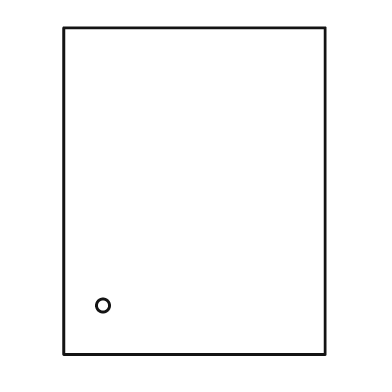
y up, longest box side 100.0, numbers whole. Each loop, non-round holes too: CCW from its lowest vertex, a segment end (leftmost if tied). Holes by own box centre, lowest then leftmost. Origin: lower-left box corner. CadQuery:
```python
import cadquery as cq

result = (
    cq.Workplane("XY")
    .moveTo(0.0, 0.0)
    .lineTo(80.0, 0.0)
    .lineTo(80.0, 100.0)
    .lineTo(0.0, 100.0)
    .close()
    .moveTo(12.0, 15.0)
    .circle(2.0)
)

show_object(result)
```